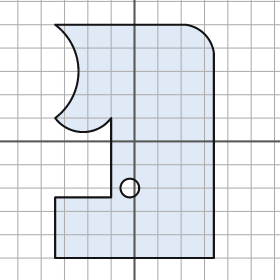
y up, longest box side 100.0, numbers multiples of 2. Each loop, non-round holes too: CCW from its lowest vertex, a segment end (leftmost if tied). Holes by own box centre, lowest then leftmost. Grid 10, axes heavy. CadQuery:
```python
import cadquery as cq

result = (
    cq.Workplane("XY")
    .moveTo(-34.0, -50.0)
    .lineTo(34.0, -50.0)
    .lineTo(34.0, 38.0)
    .threePointArc((30.0, 46.0), (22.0, 50.0))
    .lineTo(-34.0, 50.0)
    .threePointArc((-24.0, 30.0), (-34.0, 10.0))
    .threePointArc((-22.0, 4.0), (-10.0, 10.0))
    .lineTo(-10.0, -24.0)
    .lineTo(-34.0, -24.0)
    .close()
    .moveTo(-2.0, -20.0)
    .circle(4.0)
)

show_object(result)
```